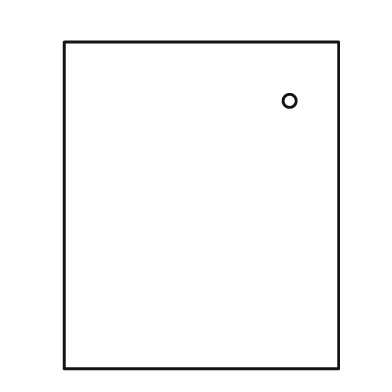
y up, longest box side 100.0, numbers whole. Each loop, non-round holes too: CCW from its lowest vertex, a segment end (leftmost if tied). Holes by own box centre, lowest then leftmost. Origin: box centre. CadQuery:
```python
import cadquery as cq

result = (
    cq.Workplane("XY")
    .moveTo(-42.0, -50.0)
    .lineTo(42.0, -50.0)
    .lineTo(42.0, 50.0)
    .lineTo(-42.0, 50.0)
    .close()
    .moveTo(27.0, 32.0)
    .circle(2.0)
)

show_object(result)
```